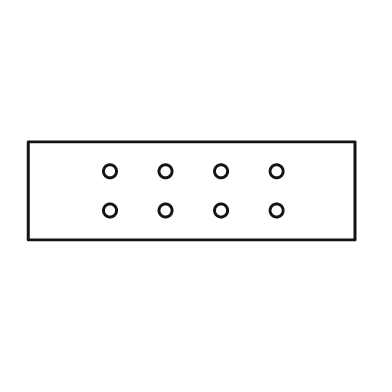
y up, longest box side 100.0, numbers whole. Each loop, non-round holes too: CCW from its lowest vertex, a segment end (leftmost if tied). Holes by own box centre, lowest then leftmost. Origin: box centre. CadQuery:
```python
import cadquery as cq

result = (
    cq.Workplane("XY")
    .moveTo(-50.0, -15.0)
    .lineTo(50.0, -15.0)
    .lineTo(50.0, 15.0)
    .lineTo(-50.0, 15.0)
    .close()
    .moveTo(-25.0, -6.0)
    .circle(2.0)
    .moveTo(-8.0, -6.0)
    .circle(2.0)
    .moveTo(9.0, -6.0)
    .circle(2.0)
    .moveTo(26.0, -6.0)
    .circle(2.0)
    .moveTo(-25.0, 6.0)
    .circle(2.0)
    .moveTo(-8.0, 6.0)
    .circle(2.0)
    .moveTo(9.0, 6.0)
    .circle(2.0)
    .moveTo(26.0, 6.0)
    .circle(2.0)
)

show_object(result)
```